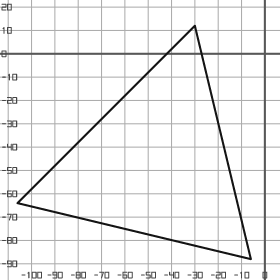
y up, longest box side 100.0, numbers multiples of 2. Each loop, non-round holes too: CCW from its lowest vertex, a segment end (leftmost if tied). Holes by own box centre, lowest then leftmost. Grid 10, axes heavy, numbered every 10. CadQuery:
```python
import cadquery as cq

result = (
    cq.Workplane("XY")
    .moveTo(-6.0, -88.0)
    .lineTo(-30.0, 12.0)
    .lineTo(-106.0, -64.0)
    .close()
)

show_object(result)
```